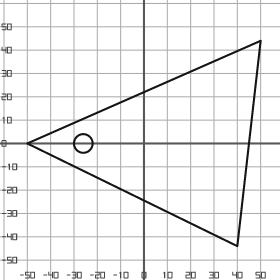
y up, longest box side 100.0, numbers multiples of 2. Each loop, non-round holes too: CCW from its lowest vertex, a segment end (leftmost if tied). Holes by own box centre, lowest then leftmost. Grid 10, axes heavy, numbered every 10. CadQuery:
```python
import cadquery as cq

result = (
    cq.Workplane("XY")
    .moveTo(40.0, -44.0)
    .lineTo(50.0, 44.0)
    .lineTo(-50.0, 0.0)
    .close()
    .moveTo(-26.0, 0.0)
    .circle(4.0)
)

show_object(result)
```